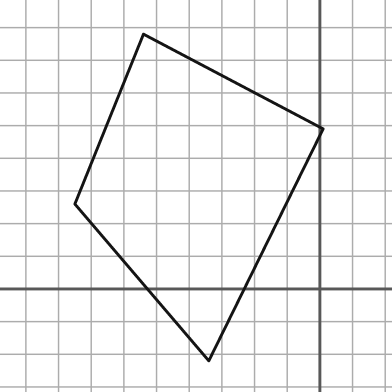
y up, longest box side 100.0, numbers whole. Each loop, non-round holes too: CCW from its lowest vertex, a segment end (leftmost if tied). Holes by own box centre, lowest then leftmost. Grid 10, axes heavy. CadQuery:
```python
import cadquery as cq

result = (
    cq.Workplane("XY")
    .moveTo(-34.0, -22.0)
    .lineTo(1.0, 49.0)
    .lineTo(-54.0, 78.0)
    .lineTo(-75.0, 26.0)
    .close()
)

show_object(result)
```